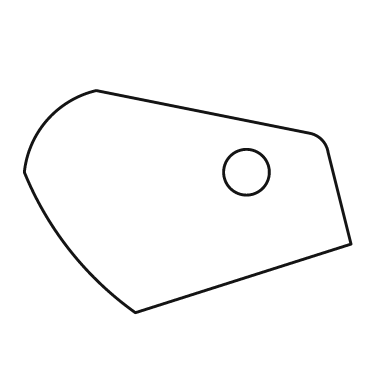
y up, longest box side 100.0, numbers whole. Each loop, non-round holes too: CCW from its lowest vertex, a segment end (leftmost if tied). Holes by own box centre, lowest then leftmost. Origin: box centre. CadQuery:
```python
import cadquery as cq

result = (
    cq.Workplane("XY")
    .moveTo(-16.0, -34.0)
    .lineTo(50.0, -13.0)
    .lineTo(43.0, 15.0)
    .threePointArc((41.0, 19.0), (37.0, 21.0))
    .lineTo(-28.0, 34.0)
    .threePointArc((-43.0, 25.0), (-50.0, 9.0))
    .threePointArc((-36.0, -15.0), (-16.0, -34.0))
    .close()
    .moveTo(18.0, 9.0)
    .circle(7.0)
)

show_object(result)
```